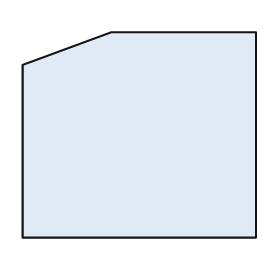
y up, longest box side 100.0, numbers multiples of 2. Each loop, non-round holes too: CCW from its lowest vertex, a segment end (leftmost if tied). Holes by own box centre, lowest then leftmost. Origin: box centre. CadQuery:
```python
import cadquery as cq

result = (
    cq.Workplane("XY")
    .moveTo(-50.0, -44.0)
    .lineTo(50.0, -44.0)
    .lineTo(50.0, 44.0)
    .lineTo(-12.0, 44.0)
    .lineTo(-50.0, 30.0)
    .close()
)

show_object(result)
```